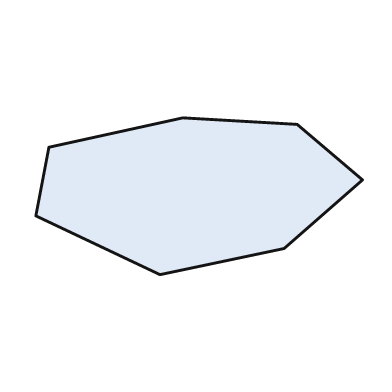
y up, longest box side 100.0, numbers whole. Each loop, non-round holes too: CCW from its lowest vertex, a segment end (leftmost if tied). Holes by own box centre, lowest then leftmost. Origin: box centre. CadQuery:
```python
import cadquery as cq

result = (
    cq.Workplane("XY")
    .moveTo(-12.0, -24.0)
    .lineTo(26.0, -16.0)
    .lineTo(50.0, 5.0)
    .lineTo(30.0, 22.0)
    .lineTo(-5.0, 24.0)
    .lineTo(-46.0, 15.0)
    .lineTo(-50.0, -6.0)
    .close()
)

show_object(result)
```